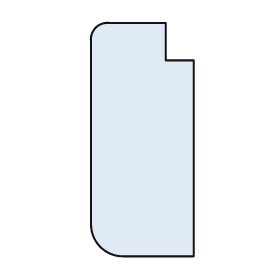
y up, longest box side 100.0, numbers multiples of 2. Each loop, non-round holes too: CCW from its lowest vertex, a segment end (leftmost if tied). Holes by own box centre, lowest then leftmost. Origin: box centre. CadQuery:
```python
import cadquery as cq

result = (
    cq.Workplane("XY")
    .moveTo(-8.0, -50.0)
    .lineTo(22.0, -50.0)
    .lineTo(22.0, 34.0)
    .lineTo(10.0, 34.0)
    .lineTo(10.0, 50.0)
    .lineTo(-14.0, 50.0)
    .threePointArc((-20.0, 48.0), (-22.0, 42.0))
    .lineTo(-22.0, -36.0)
    .threePointArc((-18.0, -46.0), (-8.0, -50.0))
    .close()
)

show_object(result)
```